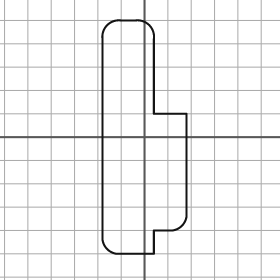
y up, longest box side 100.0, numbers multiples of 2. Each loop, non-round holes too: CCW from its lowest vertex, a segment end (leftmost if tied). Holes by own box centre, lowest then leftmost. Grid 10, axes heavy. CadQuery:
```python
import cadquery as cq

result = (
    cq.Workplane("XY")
    .moveTo(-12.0, -50.0)
    .lineTo(4.0, -50.0)
    .lineTo(4.0, -40.0)
    .lineTo(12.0, -40.0)
    .threePointArc((16.0, -38.0), (18.0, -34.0))
    .lineTo(18.0, 10.0)
    .lineTo(4.0, 10.0)
    .lineTo(4.0, 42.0)
    .threePointArc((2.0, 48.0), (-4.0, 50.0))
    .lineTo(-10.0, 50.0)
    .threePointArc((-16.0, 48.0), (-18.0, 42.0))
    .lineTo(-18.0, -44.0)
    .threePointArc((-16.0, -48.0), (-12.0, -50.0))
    .close()
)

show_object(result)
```